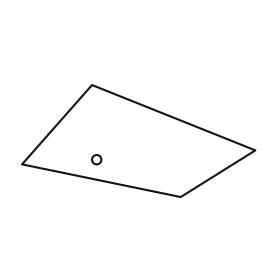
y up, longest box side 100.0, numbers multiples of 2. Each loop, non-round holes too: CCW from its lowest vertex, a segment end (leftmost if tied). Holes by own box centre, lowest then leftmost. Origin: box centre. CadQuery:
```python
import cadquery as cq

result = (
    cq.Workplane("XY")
    .moveTo(18.0, -24.0)
    .lineTo(50.0, -4.0)
    .lineTo(-20.0, 24.0)
    .lineTo(-50.0, -10.0)
    .close()
    .moveTo(-18.0, -8.0)
    .circle(2.0)
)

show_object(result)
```